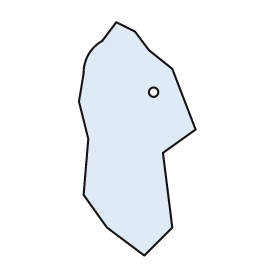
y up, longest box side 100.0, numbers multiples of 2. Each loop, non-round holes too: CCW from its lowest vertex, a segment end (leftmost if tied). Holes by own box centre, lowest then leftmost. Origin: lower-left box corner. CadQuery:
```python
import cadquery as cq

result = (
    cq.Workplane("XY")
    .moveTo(28.0, 0.0)
    .lineTo(40.0, 12.0)
    .lineTo(36.0, 44.0)
    .lineTo(50.0, 54.0)
    .lineTo(40.0, 80.0)
    .lineTo(30.0, 88.0)
    .lineTo(24.0, 96.0)
    .lineTo(16.0, 100.0)
    .lineTo(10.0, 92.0)
    .threePointArc((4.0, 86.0), (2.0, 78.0))
    .lineTo(0.0, 66.0)
    .lineTo(4.0, 50.0)
    .lineTo(2.0, 26.0)
    .lineTo(12.0, 12.0)
    .close()
    .moveTo(32.0, 70.0)
    .circle(2.0)
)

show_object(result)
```